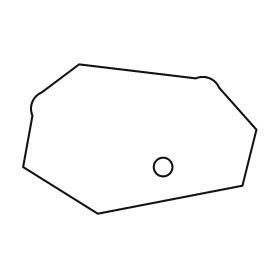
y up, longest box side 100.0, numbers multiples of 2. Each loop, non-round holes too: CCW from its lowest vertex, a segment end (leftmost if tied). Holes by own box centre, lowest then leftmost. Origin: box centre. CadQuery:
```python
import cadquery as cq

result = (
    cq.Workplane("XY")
    .moveTo(-18.0, -32.0)
    .lineTo(44.0, -20.0)
    .lineTo(50.0, 4.0)
    .lineTo(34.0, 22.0)
    .threePointArc((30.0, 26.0), (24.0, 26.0))
    .lineTo(-26.0, 32.0)
    .lineTo(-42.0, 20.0)
    .threePointArc((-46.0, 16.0), (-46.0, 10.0))
    .lineTo(-50.0, -12.0)
    .close()
    .moveTo(10.0, -12.0)
    .circle(4.0)
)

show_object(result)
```